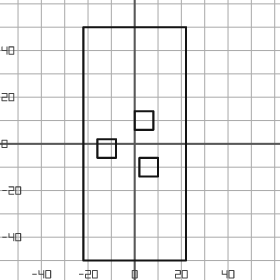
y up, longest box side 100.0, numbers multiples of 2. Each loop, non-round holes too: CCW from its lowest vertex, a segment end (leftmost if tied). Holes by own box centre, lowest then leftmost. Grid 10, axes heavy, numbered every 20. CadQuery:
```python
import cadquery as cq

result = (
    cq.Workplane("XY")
    .moveTo(-22.0, -50.0)
    .lineTo(22.0, -50.0)
    .lineTo(22.0, 50.0)
    .lineTo(-22.0, 50.0)
    .close()
    .moveTo(2.0, -14.0)
    .lineTo(10.0, -14.0)
    .lineTo(10.0, -6.0)
    .lineTo(2.0, -6.0)
    .close()
    .moveTo(-16.0, -6.0)
    .lineTo(-8.0, -6.0)
    .lineTo(-8.0, 2.0)
    .lineTo(-16.0, 2.0)
    .close()
    .moveTo(0.0, 6.0)
    .lineTo(8.0, 6.0)
    .lineTo(8.0, 14.0)
    .lineTo(0.0, 14.0)
    .close()
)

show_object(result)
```